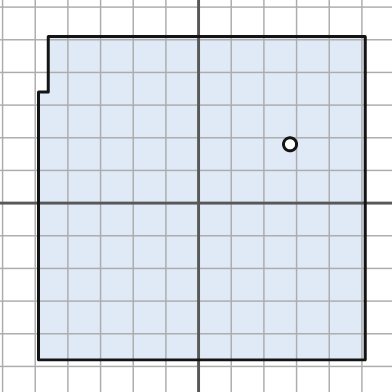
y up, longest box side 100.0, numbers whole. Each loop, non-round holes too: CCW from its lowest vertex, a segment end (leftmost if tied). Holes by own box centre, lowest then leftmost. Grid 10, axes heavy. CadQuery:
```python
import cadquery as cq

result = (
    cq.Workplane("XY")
    .moveTo(-49.0, -48.0)
    .lineTo(51.0, -48.0)
    .lineTo(51.0, 51.0)
    .lineTo(-46.0, 51.0)
    .lineTo(-46.0, 34.0)
    .lineTo(-49.0, 34.0)
    .close()
    .moveTo(28.0, 18.0)
    .circle(2.0)
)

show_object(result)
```